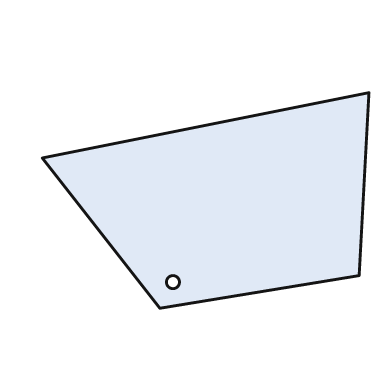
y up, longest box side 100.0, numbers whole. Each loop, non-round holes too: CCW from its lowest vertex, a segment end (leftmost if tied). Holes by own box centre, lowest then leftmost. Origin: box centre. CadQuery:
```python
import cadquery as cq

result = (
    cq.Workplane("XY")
    .moveTo(-14.0, -33.0)
    .lineTo(47.0, -23.0)
    .lineTo(50.0, 33.0)
    .lineTo(-50.0, 13.0)
    .close()
    .moveTo(-10.0, -25.0)
    .circle(2.0)
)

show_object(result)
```